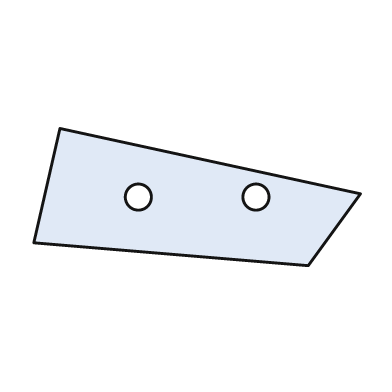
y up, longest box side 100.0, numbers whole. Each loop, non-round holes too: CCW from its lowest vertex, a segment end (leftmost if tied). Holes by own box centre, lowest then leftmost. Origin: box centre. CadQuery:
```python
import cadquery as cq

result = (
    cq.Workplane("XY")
    .moveTo(34.0, -21.0)
    .lineTo(50.0, 1.0)
    .lineTo(-42.0, 21.0)
    .lineTo(-50.0, -14.0)
    .close()
    .moveTo(-18.0, 0.0)
    .circle(4.0)
    .moveTo(18.0, 0.0)
    .circle(4.0)
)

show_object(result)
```